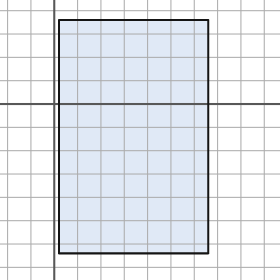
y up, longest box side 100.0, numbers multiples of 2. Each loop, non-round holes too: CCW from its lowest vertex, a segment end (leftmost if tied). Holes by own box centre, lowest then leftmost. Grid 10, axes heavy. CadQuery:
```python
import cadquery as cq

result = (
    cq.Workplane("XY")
    .moveTo(2.0, -64.0)
    .lineTo(66.0, -64.0)
    .lineTo(66.0, 36.0)
    .lineTo(2.0, 36.0)
    .close()
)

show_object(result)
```